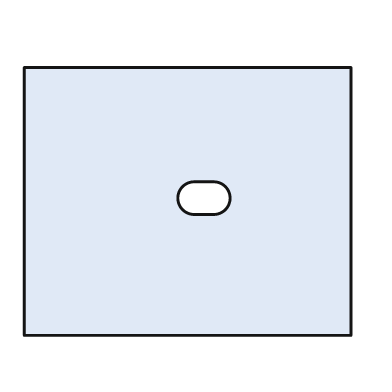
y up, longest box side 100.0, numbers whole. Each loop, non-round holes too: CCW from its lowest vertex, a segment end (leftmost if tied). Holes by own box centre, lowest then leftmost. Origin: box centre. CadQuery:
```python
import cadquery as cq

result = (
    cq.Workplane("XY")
    .moveTo(-50.0, -41.0)
    .lineTo(50.0, -41.0)
    .lineTo(50.0, 41.0)
    .lineTo(-50.0, 41.0)
    .close()
    .moveTo(2.0, -4.0)
    .lineTo(8.0, -4.0)
    .threePointArc((13.0, 1.0), (8.0, 6.0))
    .lineTo(2.0, 6.0)
    .threePointArc((-3.0, 1.0), (2.0, -4.0))
    .close()
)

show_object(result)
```